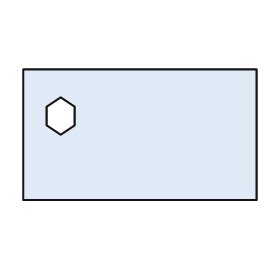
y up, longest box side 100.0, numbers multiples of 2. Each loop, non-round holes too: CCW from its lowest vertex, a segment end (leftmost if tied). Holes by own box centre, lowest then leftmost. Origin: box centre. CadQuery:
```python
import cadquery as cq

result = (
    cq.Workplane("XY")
    .moveTo(-50.0, -28.0)
    .lineTo(50.0, -28.0)
    .lineTo(50.0, 28.0)
    .lineTo(-50.0, 28.0)
    .close()
    .moveTo(-34.0, 0.0)
    .lineTo(-28.0, 4.0)
    .lineTo(-28.0, 12.0)
    .lineTo(-34.0, 16.0)
    .lineTo(-40.0, 12.0)
    .lineTo(-40.0, 4.0)
    .close()
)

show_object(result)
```